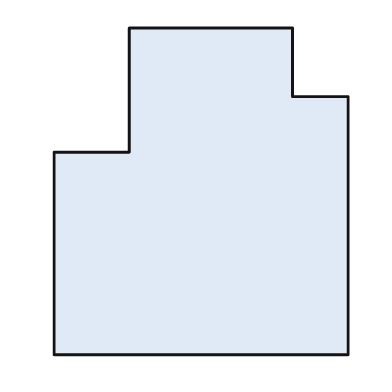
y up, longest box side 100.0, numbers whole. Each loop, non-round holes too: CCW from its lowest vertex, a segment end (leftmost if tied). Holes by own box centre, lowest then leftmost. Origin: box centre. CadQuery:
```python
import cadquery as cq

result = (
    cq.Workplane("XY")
    .moveTo(-45.0, -50.0)
    .lineTo(45.0, -50.0)
    .lineTo(45.0, 29.0)
    .lineTo(28.0, 29.0)
    .lineTo(28.0, 50.0)
    .lineTo(-22.0, 50.0)
    .lineTo(-22.0, 12.0)
    .lineTo(-45.0, 12.0)
    .close()
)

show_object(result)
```